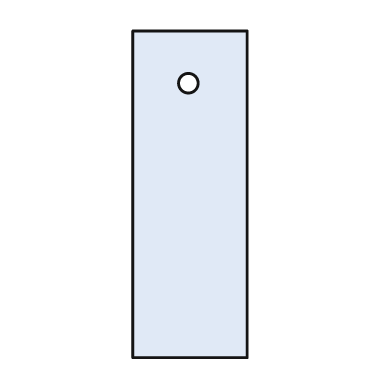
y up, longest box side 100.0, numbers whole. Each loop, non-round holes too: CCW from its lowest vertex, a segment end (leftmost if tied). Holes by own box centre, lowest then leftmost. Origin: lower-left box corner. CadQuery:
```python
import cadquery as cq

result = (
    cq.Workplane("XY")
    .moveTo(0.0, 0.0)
    .lineTo(35.0, 0.0)
    .lineTo(35.0, 100.0)
    .lineTo(0.0, 100.0)
    .close()
    .moveTo(17.0, 84.0)
    .circle(3.0)
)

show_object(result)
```